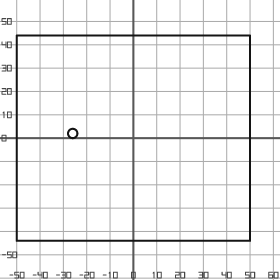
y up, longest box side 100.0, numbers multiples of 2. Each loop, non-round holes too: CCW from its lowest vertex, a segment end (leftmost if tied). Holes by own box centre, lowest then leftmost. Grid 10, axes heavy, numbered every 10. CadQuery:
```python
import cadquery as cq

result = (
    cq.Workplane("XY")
    .moveTo(-50.0, -44.0)
    .lineTo(50.0, -44.0)
    .lineTo(50.0, 44.0)
    .lineTo(-50.0, 44.0)
    .close()
    .moveTo(-26.0, 2.0)
    .circle(2.0)
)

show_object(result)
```